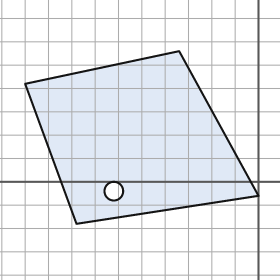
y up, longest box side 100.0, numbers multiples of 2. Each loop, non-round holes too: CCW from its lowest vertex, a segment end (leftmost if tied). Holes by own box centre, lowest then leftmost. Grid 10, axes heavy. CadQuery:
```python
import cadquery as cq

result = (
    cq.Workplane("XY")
    .moveTo(-78.0, -18.0)
    .lineTo(0.0, -6.0)
    .lineTo(-34.0, 56.0)
    .lineTo(-100.0, 42.0)
    .close()
    .moveTo(-62.0, -4.0)
    .circle(4.0)
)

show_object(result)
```